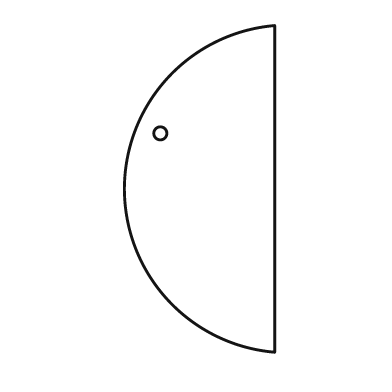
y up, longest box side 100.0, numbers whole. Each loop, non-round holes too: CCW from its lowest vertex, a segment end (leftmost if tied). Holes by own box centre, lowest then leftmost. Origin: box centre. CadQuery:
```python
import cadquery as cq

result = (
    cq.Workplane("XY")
    .moveTo(23.0, -50.0)
    .lineTo(23.0, 50.0)
    .threePointArc((-23.0, 0.0), (23.0, -50.0))
    .close()
    .moveTo(-12.0, 17.0)
    .circle(2.0)
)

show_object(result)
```